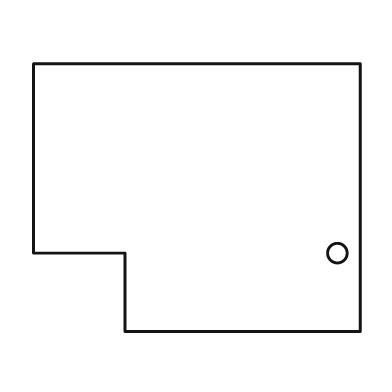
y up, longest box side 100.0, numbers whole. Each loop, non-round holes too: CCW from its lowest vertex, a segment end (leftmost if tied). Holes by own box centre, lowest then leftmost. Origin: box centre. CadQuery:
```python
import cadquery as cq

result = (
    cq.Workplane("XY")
    .moveTo(-22.0, -41.0)
    .lineTo(50.0, -41.0)
    .lineTo(50.0, 41.0)
    .lineTo(-50.0, 41.0)
    .lineTo(-50.0, -17.0)
    .lineTo(-22.0, -17.0)
    .close()
    .moveTo(43.0, -17.0)
    .circle(3.0)
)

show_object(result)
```